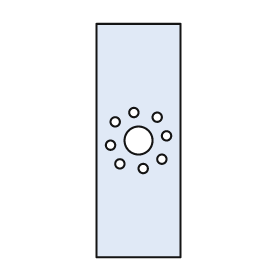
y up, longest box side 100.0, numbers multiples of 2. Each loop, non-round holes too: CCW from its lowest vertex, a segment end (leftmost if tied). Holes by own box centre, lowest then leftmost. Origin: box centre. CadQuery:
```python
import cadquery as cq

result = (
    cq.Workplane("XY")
    .moveTo(-18.0, -50.0)
    .lineTo(18.0, -50.0)
    .lineTo(18.0, 50.0)
    .lineTo(-18.0, 50.0)
    .close()
    .moveTo(2.0, -12.0)
    .circle(2.0)
    .moveTo(-8.0, -10.0)
    .circle(2.0)
    .moveTo(10.0, -8.0)
    .circle(2.0)
    .moveTo(-12.0, -2.0)
    .circle(2.0)
    .moveTo(0.0, 0.0)
    .circle(6.0)
    .moveTo(12.0, 2.0)
    .circle(2.0)
    .moveTo(-10.0, 8.0)
    .circle(2.0)
    .moveTo(8.0, 10.0)
    .circle(2.0)
    .moveTo(-2.0, 12.0)
    .circle(2.0)
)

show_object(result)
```